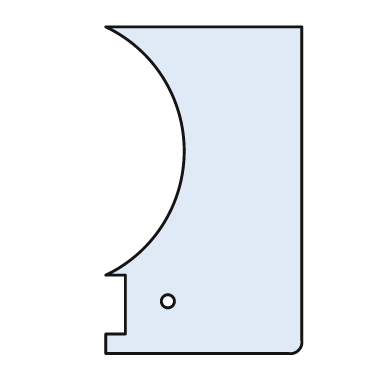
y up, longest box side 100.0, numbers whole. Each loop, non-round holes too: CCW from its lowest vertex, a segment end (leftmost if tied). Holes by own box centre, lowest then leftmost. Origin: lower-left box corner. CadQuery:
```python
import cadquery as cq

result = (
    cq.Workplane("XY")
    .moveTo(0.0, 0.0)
    .lineTo(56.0, 0.0)
    .threePointArc((59.0, 1.0), (60.0, 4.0))
    .lineTo(60.0, 100.0)
    .lineTo(0.0, 100.0)
    .threePointArc((24.0, 62.0), (0.0, 24.0))
    .lineTo(6.0, 24.0)
    .lineTo(6.0, 6.0)
    .lineTo(0.0, 6.0)
    .close()
    .moveTo(19.0, 16.0)
    .circle(2.0)
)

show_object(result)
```